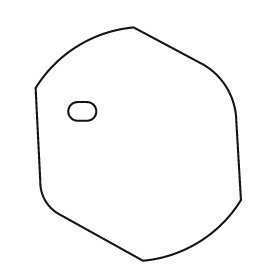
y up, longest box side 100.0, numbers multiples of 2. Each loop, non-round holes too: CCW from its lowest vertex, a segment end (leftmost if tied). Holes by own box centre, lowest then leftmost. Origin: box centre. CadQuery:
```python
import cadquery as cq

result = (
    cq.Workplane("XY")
    .moveTo(2.0, -50.0)
    .threePointArc((26.0, -42.0), (44.0, -24.0))
    .lineTo(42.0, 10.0)
    .threePointArc((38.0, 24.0), (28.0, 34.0))
    .lineTo(-2.0, 50.0)
    .threePointArc((-26.0, 42.0), (-44.0, 24.0))
    .lineTo(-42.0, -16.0)
    .threePointArc((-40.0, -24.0), (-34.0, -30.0))
    .close()
    .moveTo(-26.0, 10.0)
    .lineTo(-22.0, 10.0)
    .threePointArc((-18.0, 14.0), (-22.0, 18.0))
    .lineTo(-26.0, 18.0)
    .threePointArc((-30.0, 14.0), (-26.0, 10.0))
    .close()
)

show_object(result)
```